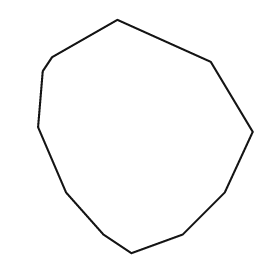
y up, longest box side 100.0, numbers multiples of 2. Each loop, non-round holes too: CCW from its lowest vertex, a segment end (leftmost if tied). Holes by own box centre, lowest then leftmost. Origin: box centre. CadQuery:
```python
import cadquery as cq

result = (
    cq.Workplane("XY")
    .moveTo(-6.0, -50.0)
    .lineTo(16.0, -42.0)
    .lineTo(34.0, -24.0)
    .lineTo(46.0, 2.0)
    .lineTo(28.0, 32.0)
    .lineTo(-12.0, 50.0)
    .lineTo(-40.0, 34.0)
    .lineTo(-44.0, 28.0)
    .lineTo(-46.0, 4.0)
    .lineTo(-34.0, -24.0)
    .lineTo(-18.0, -42.0)
    .close()
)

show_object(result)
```